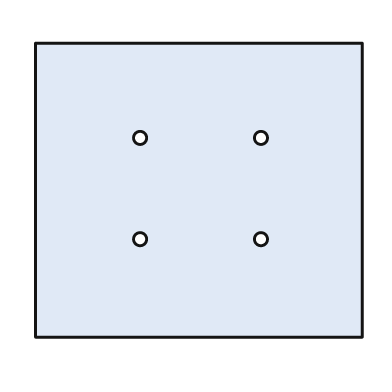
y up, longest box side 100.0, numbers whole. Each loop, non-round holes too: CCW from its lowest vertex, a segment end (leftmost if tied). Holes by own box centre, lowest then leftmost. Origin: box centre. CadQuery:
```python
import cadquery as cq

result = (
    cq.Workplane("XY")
    .moveTo(-50.0, -45.0)
    .lineTo(50.0, -45.0)
    .lineTo(50.0, 45.0)
    .lineTo(-50.0, 45.0)
    .close()
    .moveTo(-18.0, -15.0)
    .circle(2.0)
    .moveTo(19.0, -15.0)
    .circle(2.0)
    .moveTo(-18.0, 16.0)
    .circle(2.0)
    .moveTo(19.0, 16.0)
    .circle(2.0)
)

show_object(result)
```